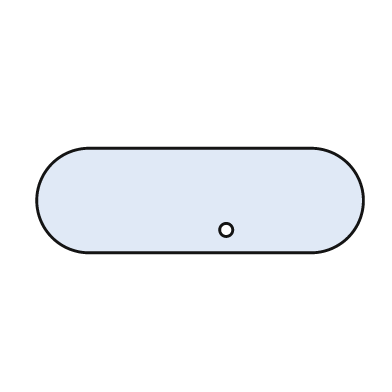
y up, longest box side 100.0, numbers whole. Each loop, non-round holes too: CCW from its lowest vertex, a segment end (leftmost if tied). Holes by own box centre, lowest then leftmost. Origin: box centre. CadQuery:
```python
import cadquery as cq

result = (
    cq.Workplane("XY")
    .moveTo(-34.0, -16.0)
    .lineTo(34.0, -16.0)
    .threePointArc((50.0, 0.0), (34.0, 16.0))
    .lineTo(-34.0, 16.0)
    .threePointArc((-50.0, 0.0), (-34.0, -16.0))
    .close()
    .moveTo(8.0, -9.0)
    .circle(2.0)
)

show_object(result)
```